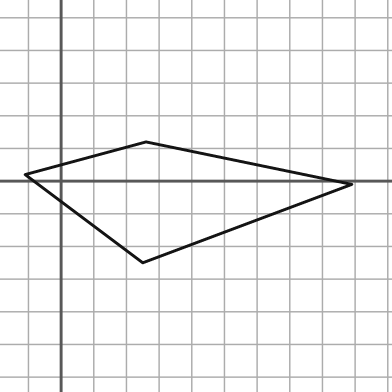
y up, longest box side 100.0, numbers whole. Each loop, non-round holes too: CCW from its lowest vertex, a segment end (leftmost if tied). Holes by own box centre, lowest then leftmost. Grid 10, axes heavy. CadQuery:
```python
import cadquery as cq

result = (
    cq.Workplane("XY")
    .moveTo(25.0, -25.0)
    .lineTo(89.0, -1.0)
    .lineTo(26.0, 12.0)
    .lineTo(-11.0, 2.0)
    .close()
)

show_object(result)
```